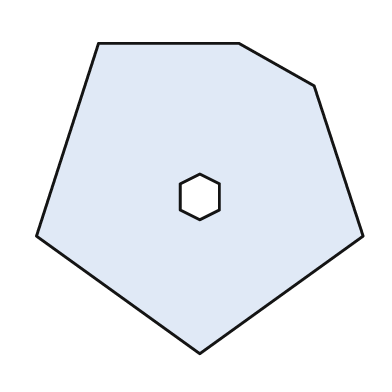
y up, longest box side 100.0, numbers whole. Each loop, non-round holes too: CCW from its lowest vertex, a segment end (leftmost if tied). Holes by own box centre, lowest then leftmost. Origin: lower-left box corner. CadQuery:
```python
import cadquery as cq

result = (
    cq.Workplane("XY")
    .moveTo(50.0, 0.0)
    .lineTo(100.0, 36.0)
    .lineTo(85.0, 82.0)
    .lineTo(62.0, 95.0)
    .lineTo(19.0, 95.0)
    .lineTo(0.0, 36.0)
    .close()
    .moveTo(50.0, 41.0)
    .lineTo(56.0, 44.0)
    .lineTo(56.0, 52.0)
    .lineTo(50.0, 55.0)
    .lineTo(44.0, 52.0)
    .lineTo(44.0, 44.0)
    .close()
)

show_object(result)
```